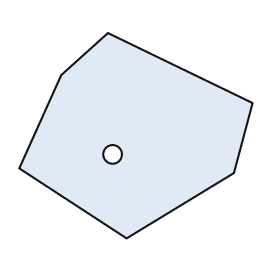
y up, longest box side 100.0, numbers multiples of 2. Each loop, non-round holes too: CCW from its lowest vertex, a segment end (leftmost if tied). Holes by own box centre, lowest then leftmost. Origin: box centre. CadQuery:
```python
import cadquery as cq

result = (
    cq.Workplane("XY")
    .moveTo(-4.0, -44.0)
    .lineTo(42.0, -16.0)
    .lineTo(50.0, 14.0)
    .lineTo(-12.0, 44.0)
    .lineTo(-32.0, 26.0)
    .lineTo(-50.0, -14.0)
    .close()
    .moveTo(-10.0, -8.0)
    .circle(4.0)
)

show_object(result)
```